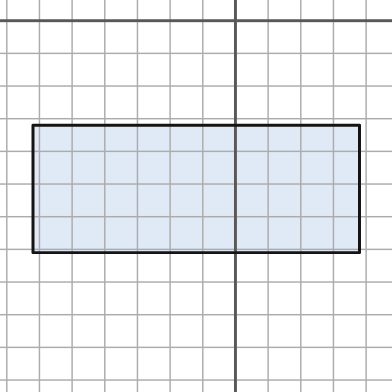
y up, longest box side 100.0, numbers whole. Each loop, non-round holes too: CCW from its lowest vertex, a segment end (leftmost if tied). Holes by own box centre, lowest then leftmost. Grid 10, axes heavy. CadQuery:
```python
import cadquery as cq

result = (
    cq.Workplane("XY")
    .moveTo(-62.0, -71.0)
    .lineTo(38.0, -71.0)
    .lineTo(38.0, -32.0)
    .lineTo(-62.0, -32.0)
    .close()
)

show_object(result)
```